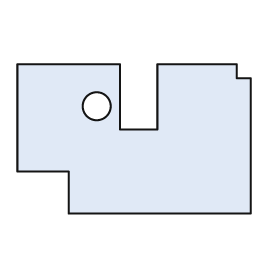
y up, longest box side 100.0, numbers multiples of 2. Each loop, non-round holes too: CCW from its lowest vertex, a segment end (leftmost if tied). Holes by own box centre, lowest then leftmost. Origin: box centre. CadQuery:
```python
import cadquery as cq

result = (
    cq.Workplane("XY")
    .moveTo(-28.0, -32.0)
    .lineTo(50.0, -32.0)
    .lineTo(50.0, 26.0)
    .lineTo(44.0, 26.0)
    .lineTo(44.0, 32.0)
    .lineTo(10.0, 32.0)
    .lineTo(10.0, 4.0)
    .lineTo(-6.0, 4.0)
    .lineTo(-6.0, 32.0)
    .lineTo(-50.0, 32.0)
    .lineTo(-50.0, -14.0)
    .lineTo(-28.0, -14.0)
    .close()
    .moveTo(-16.0, 14.0)
    .circle(6.0)
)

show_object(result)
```